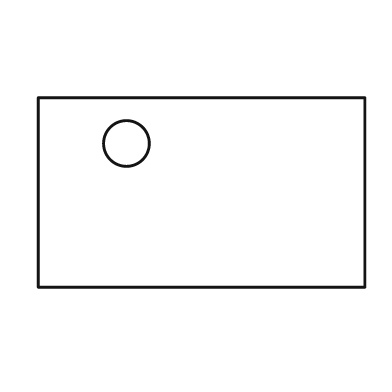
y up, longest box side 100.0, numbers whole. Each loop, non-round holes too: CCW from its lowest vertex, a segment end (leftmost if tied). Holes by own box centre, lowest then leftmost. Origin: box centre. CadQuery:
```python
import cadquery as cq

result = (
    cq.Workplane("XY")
    .moveTo(-50.0, -29.0)
    .lineTo(50.0, -29.0)
    .lineTo(50.0, 29.0)
    .lineTo(-50.0, 29.0)
    .close()
    .moveTo(-23.0, 15.0)
    .circle(7.0)
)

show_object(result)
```